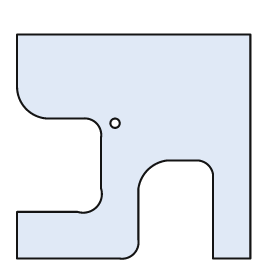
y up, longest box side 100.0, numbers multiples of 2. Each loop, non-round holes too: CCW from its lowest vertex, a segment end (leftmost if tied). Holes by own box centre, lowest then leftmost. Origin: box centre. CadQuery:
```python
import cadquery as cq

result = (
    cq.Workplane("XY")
    .moveTo(-50.0, -48.0)
    .lineTo(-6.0, -48.0)
    .threePointArc((0.0, -46.0), (2.0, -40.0))
    .lineTo(2.0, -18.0)
    .threePointArc((6.0, -10.0), (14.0, -6.0))
    .lineTo(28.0, -6.0)
    .threePointArc((32.0, -8.0), (34.0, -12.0))
    .lineTo(34.0, -48.0)
    .lineTo(50.0, -48.0)
    .lineTo(50.0, 48.0)
    .lineTo(-50.0, 48.0)
    .lineTo(-50.0, 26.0)
    .threePointArc((-46.0, 16.0), (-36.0, 12.0))
    .lineTo(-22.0, 12.0)
    .threePointArc((-16.0, 10.0), (-14.0, 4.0))
    .lineTo(-14.0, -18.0)
    .threePointArc((-16.0, -26.0), (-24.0, -28.0))
    .lineTo(-50.0, -28.0)
    .close()
    .moveTo(-8.0, 10.0)
    .circle(2.0)
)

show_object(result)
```